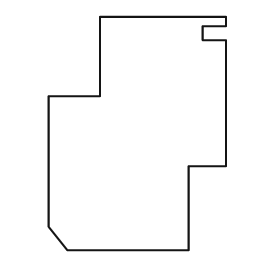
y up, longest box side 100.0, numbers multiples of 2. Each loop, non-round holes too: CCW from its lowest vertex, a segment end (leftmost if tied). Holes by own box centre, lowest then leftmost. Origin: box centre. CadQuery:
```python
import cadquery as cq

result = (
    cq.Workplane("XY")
    .moveTo(-30.0, -50.0)
    .lineTo(22.0, -50.0)
    .lineTo(22.0, -14.0)
    .lineTo(38.0, -14.0)
    .lineTo(38.0, 40.0)
    .lineTo(28.0, 40.0)
    .lineTo(28.0, 46.0)
    .lineTo(38.0, 46.0)
    .lineTo(38.0, 50.0)
    .lineTo(-16.0, 50.0)
    .lineTo(-16.0, 16.0)
    .lineTo(-38.0, 16.0)
    .lineTo(-38.0, -40.0)
    .close()
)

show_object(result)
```